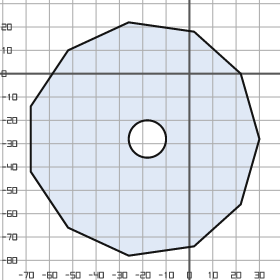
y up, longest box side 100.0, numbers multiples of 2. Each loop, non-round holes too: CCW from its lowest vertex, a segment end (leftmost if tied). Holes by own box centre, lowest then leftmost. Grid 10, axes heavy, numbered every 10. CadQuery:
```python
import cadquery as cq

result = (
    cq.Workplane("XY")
    .moveTo(-26.0, -78.0)
    .lineTo(2.0, -74.0)
    .lineTo(22.0, -56.0)
    .lineTo(30.0, -28.0)
    .lineTo(22.0, 0.0)
    .lineTo(2.0, 18.0)
    .lineTo(-26.0, 22.0)
    .lineTo(-52.0, 10.0)
    .lineTo(-68.0, -14.0)
    .lineTo(-68.0, -42.0)
    .lineTo(-52.0, -66.0)
    .close()
    .moveTo(-18.0, -28.0)
    .circle(8.0)
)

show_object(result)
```